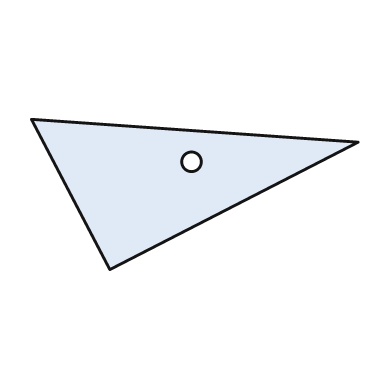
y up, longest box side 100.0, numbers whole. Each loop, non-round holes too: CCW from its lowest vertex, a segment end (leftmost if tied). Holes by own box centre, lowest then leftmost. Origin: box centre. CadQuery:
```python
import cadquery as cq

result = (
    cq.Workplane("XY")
    .moveTo(-26.0, -23.0)
    .lineTo(50.0, 16.0)
    .lineTo(-50.0, 23.0)
    .close()
    .moveTo(-1.0, 10.0)
    .circle(3.0)
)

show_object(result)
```